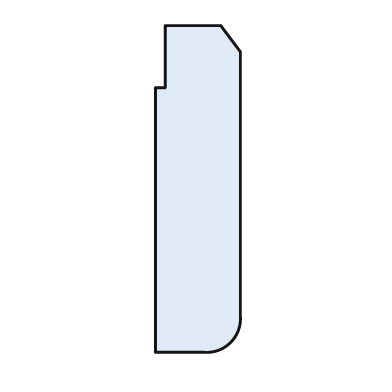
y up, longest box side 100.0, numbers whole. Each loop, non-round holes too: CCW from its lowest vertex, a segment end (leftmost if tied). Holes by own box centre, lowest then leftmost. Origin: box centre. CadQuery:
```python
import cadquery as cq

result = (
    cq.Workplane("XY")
    .moveTo(-13.0, -50.0)
    .lineTo(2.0, -50.0)
    .threePointArc((10.0, -47.0), (13.0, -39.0))
    .lineTo(13.0, 42.0)
    .lineTo(7.0, 50.0)
    .lineTo(-10.0, 50.0)
    .lineTo(-10.0, 31.0)
    .lineTo(-13.0, 31.0)
    .close()
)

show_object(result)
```